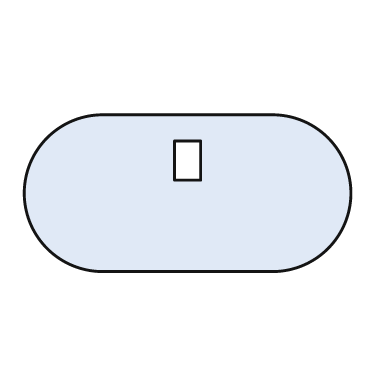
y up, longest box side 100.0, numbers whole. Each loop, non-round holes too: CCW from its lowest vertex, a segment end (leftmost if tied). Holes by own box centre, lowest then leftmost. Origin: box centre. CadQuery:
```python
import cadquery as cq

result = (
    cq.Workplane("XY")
    .moveTo(-26.0, -24.0)
    .lineTo(26.0, -24.0)
    .threePointArc((50.0, 0.0), (26.0, 24.0))
    .lineTo(-26.0, 24.0)
    .threePointArc((-50.0, 0.0), (-26.0, -24.0))
    .close()
    .moveTo(-4.0, 4.0)
    .lineTo(4.0, 4.0)
    .lineTo(4.0, 16.0)
    .lineTo(-4.0, 16.0)
    .close()
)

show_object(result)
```